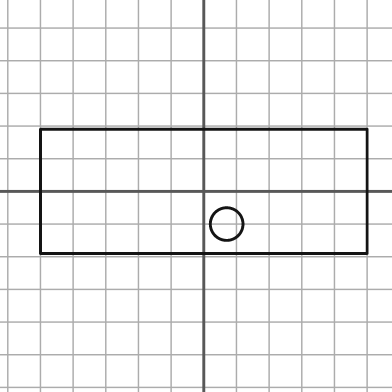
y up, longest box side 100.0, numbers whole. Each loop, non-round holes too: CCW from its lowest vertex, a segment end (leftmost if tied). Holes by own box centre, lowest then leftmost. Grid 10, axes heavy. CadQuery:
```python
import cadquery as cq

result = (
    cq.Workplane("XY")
    .moveTo(-50.0, -19.0)
    .lineTo(50.0, -19.0)
    .lineTo(50.0, 19.0)
    .lineTo(-50.0, 19.0)
    .close()
    .moveTo(7.0, -10.0)
    .circle(5.0)
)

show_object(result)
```